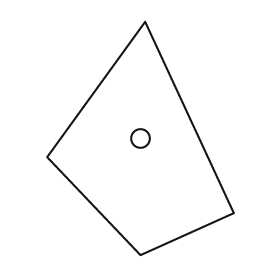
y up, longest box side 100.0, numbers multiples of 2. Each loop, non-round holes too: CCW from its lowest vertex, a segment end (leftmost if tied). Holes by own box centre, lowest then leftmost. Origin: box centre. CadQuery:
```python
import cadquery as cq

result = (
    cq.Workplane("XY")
    .moveTo(0.0, -50.0)
    .lineTo(40.0, -32.0)
    .lineTo(2.0, 50.0)
    .lineTo(-40.0, -8.0)
    .close()
    .moveTo(0.0, 0.0)
    .circle(4.0)
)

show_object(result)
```